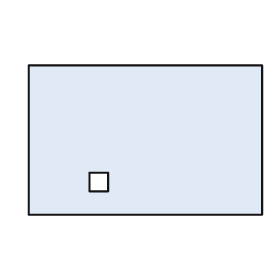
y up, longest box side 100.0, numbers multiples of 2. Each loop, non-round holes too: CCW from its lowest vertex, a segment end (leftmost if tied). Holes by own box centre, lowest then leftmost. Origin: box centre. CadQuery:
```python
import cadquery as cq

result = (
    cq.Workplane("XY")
    .moveTo(-50.0, -32.0)
    .lineTo(50.0, -32.0)
    .lineTo(50.0, 32.0)
    .lineTo(-50.0, 32.0)
    .close()
    .moveTo(-24.0, -22.0)
    .lineTo(-16.0, -22.0)
    .lineTo(-16.0, -14.0)
    .lineTo(-24.0, -14.0)
    .close()
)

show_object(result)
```